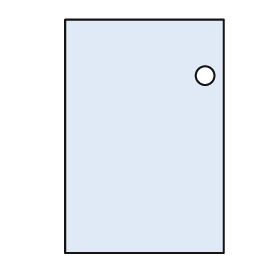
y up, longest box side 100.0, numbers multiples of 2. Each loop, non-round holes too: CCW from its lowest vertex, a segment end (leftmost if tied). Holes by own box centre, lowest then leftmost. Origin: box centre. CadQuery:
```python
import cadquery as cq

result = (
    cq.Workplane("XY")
    .moveTo(-34.0, -50.0)
    .lineTo(34.0, -50.0)
    .lineTo(34.0, 50.0)
    .lineTo(-34.0, 50.0)
    .close()
    .moveTo(26.0, 26.0)
    .circle(4.0)
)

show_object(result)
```